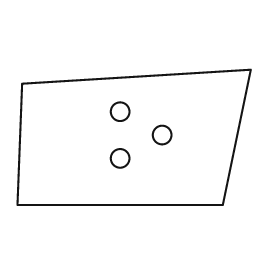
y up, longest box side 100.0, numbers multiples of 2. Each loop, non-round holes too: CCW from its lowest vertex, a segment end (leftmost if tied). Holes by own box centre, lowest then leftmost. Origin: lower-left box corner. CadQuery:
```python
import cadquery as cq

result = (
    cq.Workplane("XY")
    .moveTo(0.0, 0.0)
    .lineTo(88.0, 0.0)
    .lineTo(100.0, 58.0)
    .lineTo(2.0, 52.0)
    .close()
    .moveTo(44.0, 20.0)
    .circle(4.0)
    .moveTo(62.0, 30.0)
    .circle(4.0)
    .moveTo(44.0, 40.0)
    .circle(4.0)
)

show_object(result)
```